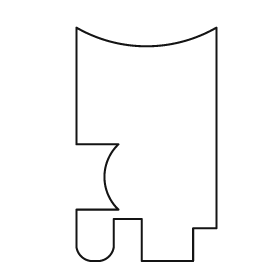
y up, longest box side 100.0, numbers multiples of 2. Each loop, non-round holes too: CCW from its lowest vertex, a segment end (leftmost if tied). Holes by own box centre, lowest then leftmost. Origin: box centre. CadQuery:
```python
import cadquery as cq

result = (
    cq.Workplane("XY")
    .moveTo(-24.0, -50.0)
    .lineTo(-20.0, -50.0)
    .threePointArc((-16.0, -48.0), (-14.0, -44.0))
    .lineTo(-14.0, -32.0)
    .lineTo(-2.0, -32.0)
    .lineTo(-2.0, -50.0)
    .lineTo(20.0, -50.0)
    .lineTo(20.0, -36.0)
    .lineTo(30.0, -36.0)
    .lineTo(30.0, 50.0)
    .threePointArc((0.0, 42.0), (-30.0, 50.0))
    .lineTo(-30.0, 0.0)
    .lineTo(-12.0, 0.0)
    .threePointArc((-18.0, -14.0), (-12.0, -28.0))
    .lineTo(-30.0, -28.0)
    .lineTo(-30.0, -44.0)
    .threePointArc((-28.0, -48.0), (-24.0, -50.0))
    .close()
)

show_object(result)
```